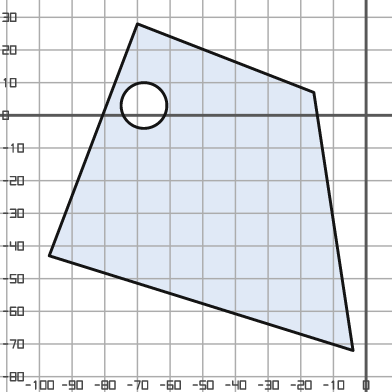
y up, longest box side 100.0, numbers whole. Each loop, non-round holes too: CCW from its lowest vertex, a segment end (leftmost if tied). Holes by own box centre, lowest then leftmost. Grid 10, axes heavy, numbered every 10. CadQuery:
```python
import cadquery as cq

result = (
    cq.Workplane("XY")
    .moveTo(-4.0, -72.0)
    .lineTo(-16.0, 7.0)
    .lineTo(-70.0, 28.0)
    .lineTo(-97.0, -43.0)
    .close()
    .moveTo(-68.0, 3.0)
    .circle(7.0)
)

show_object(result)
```